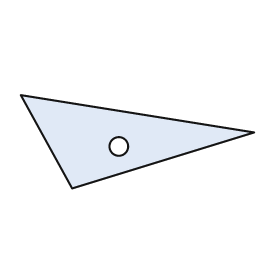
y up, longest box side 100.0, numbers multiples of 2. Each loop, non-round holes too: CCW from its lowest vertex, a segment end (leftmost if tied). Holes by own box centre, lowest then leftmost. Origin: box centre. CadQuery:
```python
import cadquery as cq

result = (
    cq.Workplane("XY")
    .moveTo(-28.0, -20.0)
    .lineTo(50.0, 4.0)
    .lineTo(-50.0, 20.0)
    .close()
    .moveTo(-8.0, -2.0)
    .circle(4.0)
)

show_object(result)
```